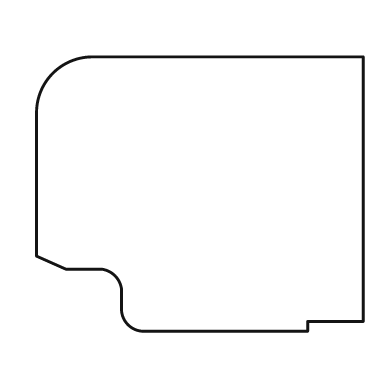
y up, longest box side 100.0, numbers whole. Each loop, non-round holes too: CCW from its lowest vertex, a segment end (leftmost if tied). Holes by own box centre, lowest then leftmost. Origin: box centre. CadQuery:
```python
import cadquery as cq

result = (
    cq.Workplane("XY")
    .moveTo(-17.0, -42.0)
    .lineTo(33.0, -42.0)
    .lineTo(33.0, -39.0)
    .lineTo(50.0, -39.0)
    .lineTo(50.0, 42.0)
    .lineTo(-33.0, 42.0)
    .threePointArc((-45.0, 37.0), (-50.0, 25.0))
    .lineTo(-50.0, -19.0)
    .lineTo(-41.0, -23.0)
    .lineTo(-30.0, -23.0)
    .threePointArc((-26.0, -25.0), (-24.0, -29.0))
    .lineTo(-24.0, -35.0)
    .threePointArc((-22.0, -40.0), (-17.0, -42.0))
    .close()
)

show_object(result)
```